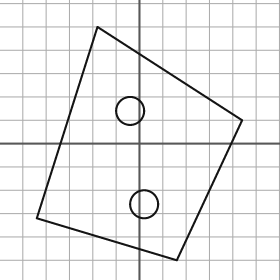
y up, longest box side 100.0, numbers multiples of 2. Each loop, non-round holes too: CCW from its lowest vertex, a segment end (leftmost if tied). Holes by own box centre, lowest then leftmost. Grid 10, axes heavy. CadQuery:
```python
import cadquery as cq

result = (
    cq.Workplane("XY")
    .moveTo(16.0, -50.0)
    .lineTo(44.0, 10.0)
    .lineTo(-18.0, 50.0)
    .lineTo(-44.0, -32.0)
    .close()
    .moveTo(2.0, -26.0)
    .circle(6.0)
    .moveTo(-4.0, 14.0)
    .circle(6.0)
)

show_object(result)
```